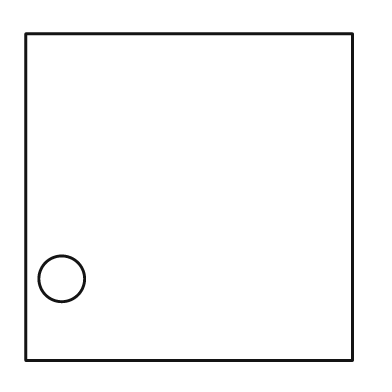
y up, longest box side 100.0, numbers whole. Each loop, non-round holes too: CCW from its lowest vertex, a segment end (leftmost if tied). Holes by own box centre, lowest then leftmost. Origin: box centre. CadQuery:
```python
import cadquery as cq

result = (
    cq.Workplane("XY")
    .moveTo(-50.0, -50.0)
    .lineTo(50.0, -50.0)
    .lineTo(50.0, 50.0)
    .lineTo(-50.0, 50.0)
    .close()
    .moveTo(-39.0, -25.0)
    .circle(7.0)
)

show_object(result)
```